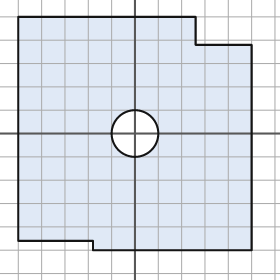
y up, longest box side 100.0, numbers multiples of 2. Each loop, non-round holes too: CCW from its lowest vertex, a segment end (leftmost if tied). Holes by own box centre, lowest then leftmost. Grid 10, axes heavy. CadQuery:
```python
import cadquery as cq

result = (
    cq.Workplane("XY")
    .moveTo(-18.0, -50.0)
    .lineTo(50.0, -50.0)
    .lineTo(50.0, 38.0)
    .lineTo(26.0, 38.0)
    .lineTo(26.0, 50.0)
    .lineTo(-50.0, 50.0)
    .lineTo(-50.0, -46.0)
    .lineTo(-18.0, -46.0)
    .close()
    .moveTo(0.0, 0.0)
    .circle(10.0)
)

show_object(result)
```